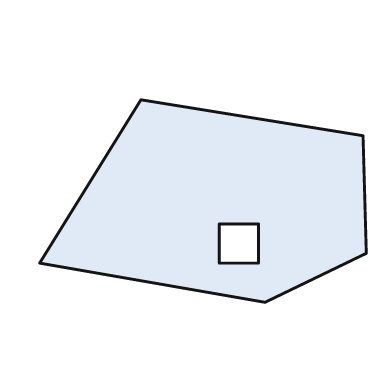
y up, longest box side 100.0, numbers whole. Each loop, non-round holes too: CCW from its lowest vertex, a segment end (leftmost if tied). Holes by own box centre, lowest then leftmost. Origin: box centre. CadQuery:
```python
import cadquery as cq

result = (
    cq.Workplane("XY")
    .moveTo(19.0, -31.0)
    .lineTo(50.0, -16.0)
    .lineTo(49.0, 20.0)
    .lineTo(-19.0, 31.0)
    .lineTo(-50.0, -19.0)
    .close()
    .moveTo(5.0, -19.0)
    .lineTo(17.0, -19.0)
    .lineTo(17.0, -7.0)
    .lineTo(5.0, -7.0)
    .close()
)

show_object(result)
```